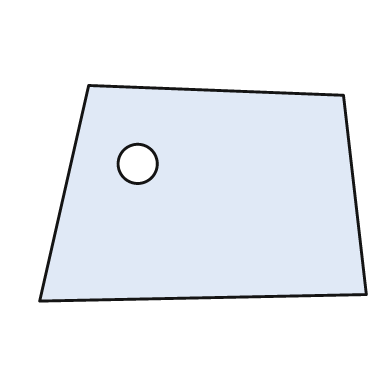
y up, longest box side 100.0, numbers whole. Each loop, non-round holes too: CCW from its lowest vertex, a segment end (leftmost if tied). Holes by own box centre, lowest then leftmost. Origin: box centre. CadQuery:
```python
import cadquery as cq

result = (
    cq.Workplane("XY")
    .moveTo(-50.0, -33.0)
    .lineTo(50.0, -31.0)
    .lineTo(43.0, 30.0)
    .lineTo(-35.0, 33.0)
    .close()
    .moveTo(-20.0, 9.0)
    .circle(6.0)
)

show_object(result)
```